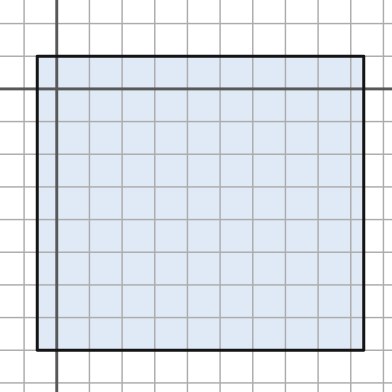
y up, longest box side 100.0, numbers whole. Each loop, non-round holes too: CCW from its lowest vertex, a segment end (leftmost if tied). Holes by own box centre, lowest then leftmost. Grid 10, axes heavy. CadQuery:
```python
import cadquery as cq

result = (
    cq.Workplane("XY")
    .moveTo(-6.0, -80.0)
    .lineTo(94.0, -80.0)
    .lineTo(94.0, 10.0)
    .lineTo(-6.0, 10.0)
    .close()
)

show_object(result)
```